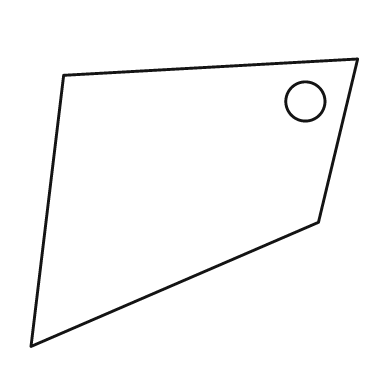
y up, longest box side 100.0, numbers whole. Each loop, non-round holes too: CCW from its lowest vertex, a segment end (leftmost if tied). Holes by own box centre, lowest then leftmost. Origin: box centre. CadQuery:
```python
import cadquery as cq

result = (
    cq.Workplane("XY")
    .moveTo(-50.0, -44.0)
    .lineTo(38.0, -6.0)
    .lineTo(50.0, 44.0)
    .lineTo(-40.0, 39.0)
    .close()
    .moveTo(34.0, 31.0)
    .circle(6.0)
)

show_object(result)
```